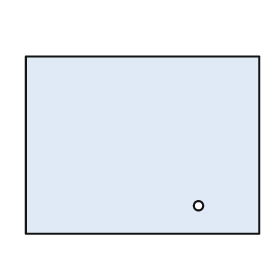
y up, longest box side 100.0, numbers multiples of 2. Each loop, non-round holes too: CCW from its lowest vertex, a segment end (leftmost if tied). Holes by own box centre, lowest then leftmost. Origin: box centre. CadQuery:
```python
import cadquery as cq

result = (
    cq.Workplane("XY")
    .moveTo(-50.0, -38.0)
    .lineTo(50.0, -38.0)
    .lineTo(50.0, 38.0)
    .lineTo(-50.0, 38.0)
    .close()
    .moveTo(24.0, -26.0)
    .circle(2.0)
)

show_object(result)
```